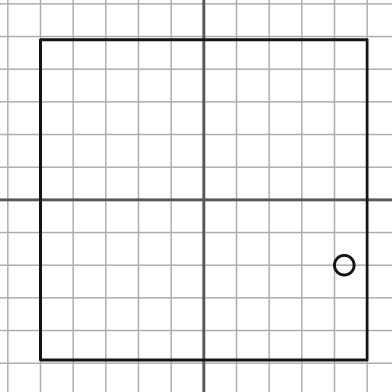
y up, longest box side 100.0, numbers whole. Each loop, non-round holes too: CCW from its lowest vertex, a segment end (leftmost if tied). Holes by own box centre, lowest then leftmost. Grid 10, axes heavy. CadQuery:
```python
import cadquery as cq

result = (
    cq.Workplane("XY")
    .moveTo(-50.0, -49.0)
    .lineTo(50.0, -49.0)
    .lineTo(50.0, 49.0)
    .lineTo(-50.0, 49.0)
    .close()
    .moveTo(43.0, -20.0)
    .circle(3.0)
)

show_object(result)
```